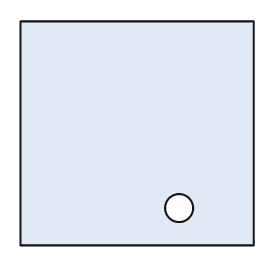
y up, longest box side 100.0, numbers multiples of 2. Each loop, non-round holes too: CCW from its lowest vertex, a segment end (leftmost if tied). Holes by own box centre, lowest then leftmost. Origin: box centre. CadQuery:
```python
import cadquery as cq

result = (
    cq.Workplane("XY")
    .moveTo(-50.0, -48.0)
    .lineTo(50.0, -48.0)
    .lineTo(50.0, 48.0)
    .lineTo(-50.0, 48.0)
    .close()
    .moveTo(18.0, -32.0)
    .circle(6.0)
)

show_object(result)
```